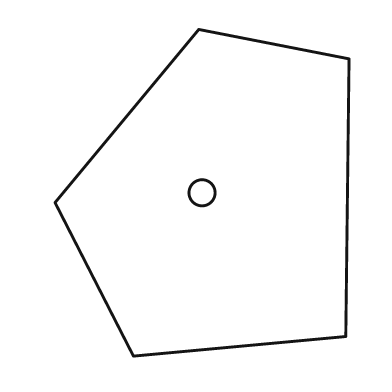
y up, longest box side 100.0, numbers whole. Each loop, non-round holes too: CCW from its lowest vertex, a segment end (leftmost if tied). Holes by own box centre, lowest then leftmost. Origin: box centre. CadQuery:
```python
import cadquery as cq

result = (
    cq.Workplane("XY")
    .moveTo(-21.0, -50.0)
    .lineTo(44.0, -44.0)
    .lineTo(45.0, 41.0)
    .lineTo(-1.0, 50.0)
    .lineTo(-45.0, -3.0)
    .close()
    .moveTo(0.0, 0.0)
    .circle(4.0)
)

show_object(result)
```